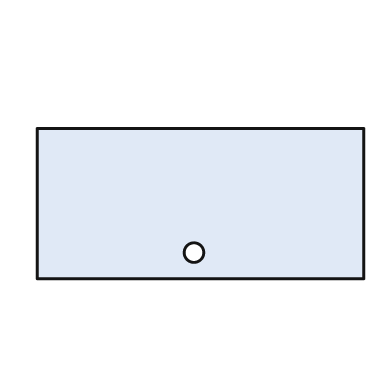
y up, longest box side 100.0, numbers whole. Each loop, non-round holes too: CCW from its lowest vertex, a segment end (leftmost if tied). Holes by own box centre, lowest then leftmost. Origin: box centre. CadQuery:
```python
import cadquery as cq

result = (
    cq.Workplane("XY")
    .moveTo(-50.0, -23.0)
    .lineTo(50.0, -23.0)
    .lineTo(50.0, 23.0)
    .lineTo(-50.0, 23.0)
    .close()
    .moveTo(-2.0, -15.0)
    .circle(3.0)
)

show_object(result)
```